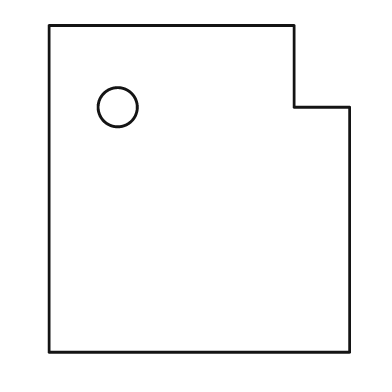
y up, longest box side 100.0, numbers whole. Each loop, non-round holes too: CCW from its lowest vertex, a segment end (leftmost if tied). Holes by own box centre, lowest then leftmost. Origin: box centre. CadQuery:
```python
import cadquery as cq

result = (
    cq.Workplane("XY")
    .moveTo(-46.0, -50.0)
    .lineTo(46.0, -50.0)
    .lineTo(46.0, 25.0)
    .lineTo(29.0, 25.0)
    .lineTo(29.0, 50.0)
    .lineTo(-46.0, 50.0)
    .close()
    .moveTo(-25.0, 25.0)
    .circle(6.0)
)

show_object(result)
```